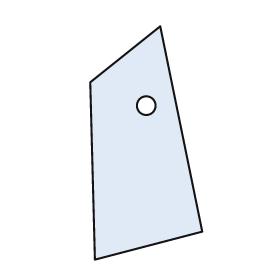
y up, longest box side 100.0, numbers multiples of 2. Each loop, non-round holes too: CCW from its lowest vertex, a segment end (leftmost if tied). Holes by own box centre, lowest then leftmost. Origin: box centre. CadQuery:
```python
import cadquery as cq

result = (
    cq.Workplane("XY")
    .moveTo(-22.0, -50.0)
    .lineTo(24.0, -38.0)
    .lineTo(6.0, 50.0)
    .lineTo(-24.0, 26.0)
    .close()
    .moveTo(0.0, 16.0)
    .circle(4.0)
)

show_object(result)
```